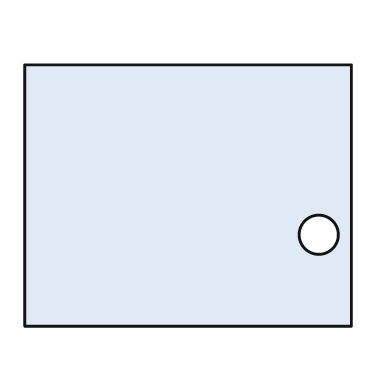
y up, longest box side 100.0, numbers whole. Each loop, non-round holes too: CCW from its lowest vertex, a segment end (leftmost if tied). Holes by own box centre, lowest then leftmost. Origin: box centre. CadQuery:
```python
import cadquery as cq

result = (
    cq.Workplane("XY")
    .moveTo(-50.0, -40.0)
    .lineTo(50.0, -40.0)
    .lineTo(50.0, 40.0)
    .lineTo(-50.0, 40.0)
    .close()
    .moveTo(40.0, -12.0)
    .circle(6.0)
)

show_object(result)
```